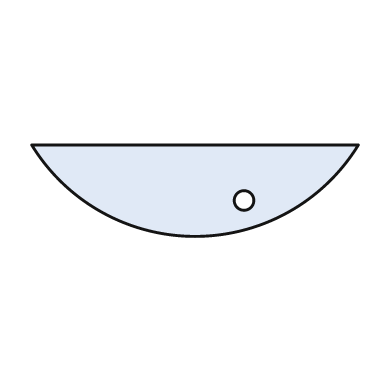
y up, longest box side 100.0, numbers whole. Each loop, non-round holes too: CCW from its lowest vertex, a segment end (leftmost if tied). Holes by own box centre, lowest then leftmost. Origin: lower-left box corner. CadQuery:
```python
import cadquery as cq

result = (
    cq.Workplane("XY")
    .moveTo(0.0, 28.0)
    .threePointArc((50.0, 0.0), (100.0, 28.0))
    .close()
    .moveTo(65.0, 11.0)
    .circle(3.0)
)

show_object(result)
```